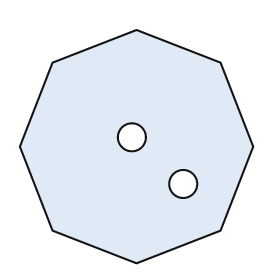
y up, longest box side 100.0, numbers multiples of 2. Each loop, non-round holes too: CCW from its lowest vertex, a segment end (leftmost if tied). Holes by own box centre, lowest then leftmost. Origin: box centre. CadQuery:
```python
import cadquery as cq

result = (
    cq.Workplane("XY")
    .moveTo(0.0, -50.0)
    .lineTo(36.0, -36.0)
    .lineTo(50.0, 0.0)
    .lineTo(36.0, 36.0)
    .lineTo(0.0, 50.0)
    .lineTo(-36.0, 36.0)
    .lineTo(-50.0, 0.0)
    .lineTo(-36.0, -36.0)
    .close()
    .moveTo(20.0, -16.0)
    .circle(6.0)
    .moveTo(-2.0, 4.0)
    .circle(6.0)
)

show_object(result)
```